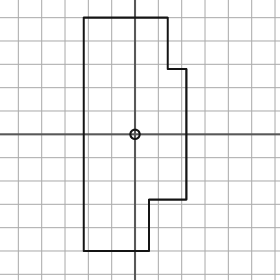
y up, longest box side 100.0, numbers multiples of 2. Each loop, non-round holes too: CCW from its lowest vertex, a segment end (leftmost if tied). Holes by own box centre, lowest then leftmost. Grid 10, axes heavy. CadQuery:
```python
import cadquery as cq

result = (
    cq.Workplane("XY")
    .moveTo(-22.0, -50.0)
    .lineTo(6.0, -50.0)
    .lineTo(6.0, -28.0)
    .lineTo(22.0, -28.0)
    .lineTo(22.0, 28.0)
    .lineTo(14.0, 28.0)
    .lineTo(14.0, 50.0)
    .lineTo(-22.0, 50.0)
    .close()
    .moveTo(0.0, 0.0)
    .circle(2.0)
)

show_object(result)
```